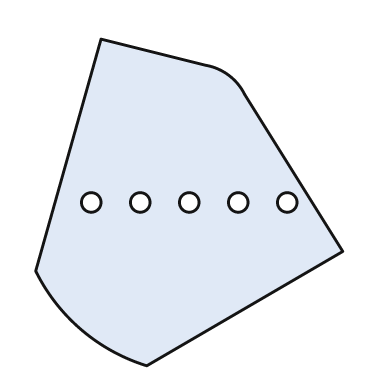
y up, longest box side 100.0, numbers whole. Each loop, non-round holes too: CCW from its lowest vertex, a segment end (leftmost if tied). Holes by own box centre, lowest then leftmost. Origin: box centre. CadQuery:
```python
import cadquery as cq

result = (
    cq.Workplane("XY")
    .moveTo(-13.0, -50.0)
    .lineTo(47.0, -15.0)
    .lineTo(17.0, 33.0)
    .threePointArc((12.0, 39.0), (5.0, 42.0))
    .lineTo(-27.0, 50.0)
    .lineTo(-47.0, -21.0)
    .threePointArc((-33.0, -39.0), (-13.0, -50.0))
    .close()
    .moveTo(-30.0, 0.0)
    .circle(3.0)
    .moveTo(-15.0, 0.0)
    .circle(3.0)
    .moveTo(0.0, 0.0)
    .circle(3.0)
    .moveTo(15.0, 0.0)
    .circle(3.0)
    .moveTo(30.0, 0.0)
    .circle(3.0)
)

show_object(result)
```